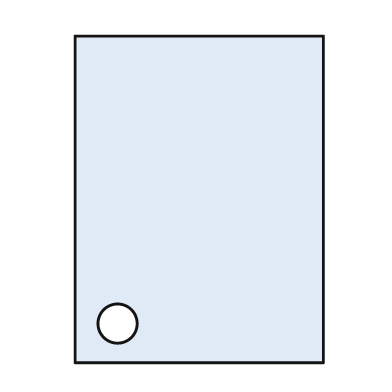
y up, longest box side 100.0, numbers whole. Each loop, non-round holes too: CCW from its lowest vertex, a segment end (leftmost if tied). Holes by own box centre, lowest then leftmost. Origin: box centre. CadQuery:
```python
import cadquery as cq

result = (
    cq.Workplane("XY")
    .moveTo(-38.0, -50.0)
    .lineTo(38.0, -50.0)
    .lineTo(38.0, 50.0)
    .lineTo(-38.0, 50.0)
    .close()
    .moveTo(-25.0, -38.0)
    .circle(6.0)
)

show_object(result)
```